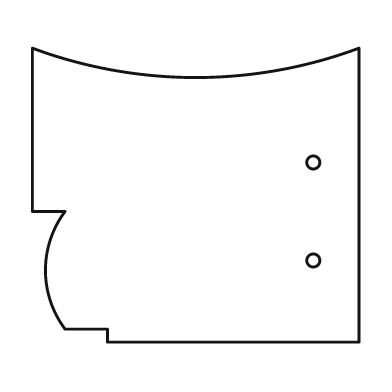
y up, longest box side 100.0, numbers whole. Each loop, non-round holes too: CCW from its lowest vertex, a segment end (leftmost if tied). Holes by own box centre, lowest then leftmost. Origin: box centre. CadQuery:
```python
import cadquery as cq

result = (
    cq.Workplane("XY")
    .moveTo(-27.0, -45.0)
    .lineTo(50.0, -45.0)
    .lineTo(50.0, 45.0)
    .threePointArc((0.0, 36.0), (-50.0, 45.0))
    .lineTo(-50.0, -5.0)
    .lineTo(-40.0, -5.0)
    .threePointArc((-46.0, -23.0), (-40.0, -41.0))
    .lineTo(-27.0, -41.0)
    .close()
    .moveTo(36.0, -20.0)
    .circle(2.0)
    .moveTo(36.0, 10.0)
    .circle(2.0)
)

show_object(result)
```